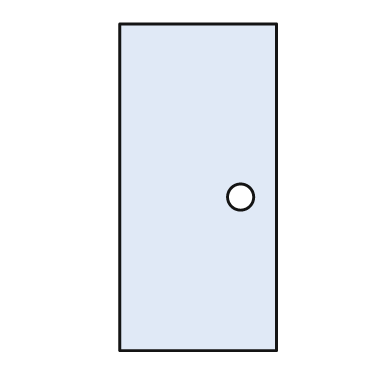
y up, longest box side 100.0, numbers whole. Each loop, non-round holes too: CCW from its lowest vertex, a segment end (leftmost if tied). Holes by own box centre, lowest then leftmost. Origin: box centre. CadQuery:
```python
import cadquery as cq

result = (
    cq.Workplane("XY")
    .moveTo(-24.0, -50.0)
    .lineTo(24.0, -50.0)
    .lineTo(24.0, 50.0)
    .lineTo(-24.0, 50.0)
    .close()
    .moveTo(13.0, -3.0)
    .circle(4.0)
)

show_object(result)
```